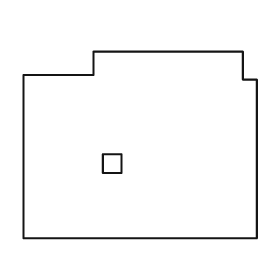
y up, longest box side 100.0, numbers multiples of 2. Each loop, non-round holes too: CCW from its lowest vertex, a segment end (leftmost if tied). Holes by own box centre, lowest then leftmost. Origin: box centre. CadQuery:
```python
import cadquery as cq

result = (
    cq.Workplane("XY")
    .moveTo(-50.0, -40.0)
    .lineTo(50.0, -40.0)
    .lineTo(50.0, 28.0)
    .lineTo(44.0, 28.0)
    .lineTo(44.0, 40.0)
    .lineTo(-20.0, 40.0)
    .lineTo(-20.0, 30.0)
    .lineTo(-50.0, 30.0)
    .close()
    .moveTo(-16.0, -12.0)
    .lineTo(-8.0, -12.0)
    .lineTo(-8.0, -4.0)
    .lineTo(-16.0, -4.0)
    .close()
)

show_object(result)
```